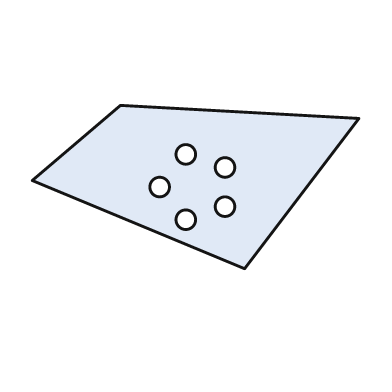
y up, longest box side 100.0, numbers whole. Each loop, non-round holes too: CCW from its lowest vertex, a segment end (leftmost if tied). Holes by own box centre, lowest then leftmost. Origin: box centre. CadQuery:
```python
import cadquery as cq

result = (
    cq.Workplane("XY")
    .moveTo(15.0, -25.0)
    .lineTo(50.0, 21.0)
    .lineTo(-23.0, 25.0)
    .lineTo(-50.0, 2.0)
    .close()
    .moveTo(-3.0, -10.0)
    .circle(3.0)
    .moveTo(9.0, -6.0)
    .circle(3.0)
    .moveTo(-11.0, 0.0)
    .circle(3.0)
    .moveTo(9.0, 6.0)
    .circle(3.0)
    .moveTo(-3.0, 10.0)
    .circle(3.0)
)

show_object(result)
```